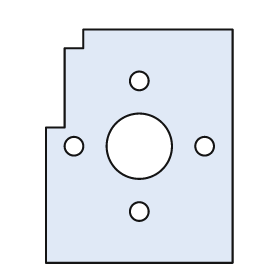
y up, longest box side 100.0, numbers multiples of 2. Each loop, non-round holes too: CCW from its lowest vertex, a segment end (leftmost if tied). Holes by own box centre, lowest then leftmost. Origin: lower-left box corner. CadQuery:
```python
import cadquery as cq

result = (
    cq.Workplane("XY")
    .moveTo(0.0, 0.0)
    .lineTo(80.0, 0.0)
    .lineTo(80.0, 100.0)
    .lineTo(16.0, 100.0)
    .lineTo(16.0, 92.0)
    .lineTo(8.0, 92.0)
    .lineTo(8.0, 58.0)
    .lineTo(0.0, 58.0)
    .close()
    .moveTo(40.0, 22.0)
    .circle(4.0)
    .moveTo(12.0, 50.0)
    .circle(4.0)
    .moveTo(40.0, 50.0)
    .circle(14.0)
    .moveTo(68.0, 50.0)
    .circle(4.0)
    .moveTo(40.0, 78.0)
    .circle(4.0)
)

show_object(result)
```